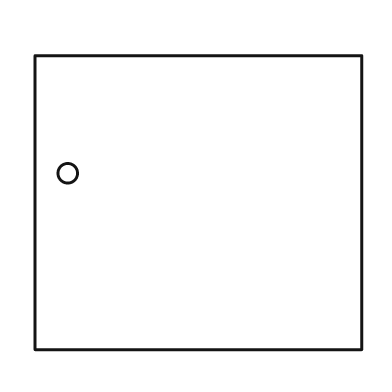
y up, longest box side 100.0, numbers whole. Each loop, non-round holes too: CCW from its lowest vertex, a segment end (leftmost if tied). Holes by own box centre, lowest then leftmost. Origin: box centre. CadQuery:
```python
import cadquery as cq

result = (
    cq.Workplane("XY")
    .moveTo(-50.0, -45.0)
    .lineTo(50.0, -45.0)
    .lineTo(50.0, 45.0)
    .lineTo(-50.0, 45.0)
    .close()
    .moveTo(-40.0, 9.0)
    .circle(3.0)
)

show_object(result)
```